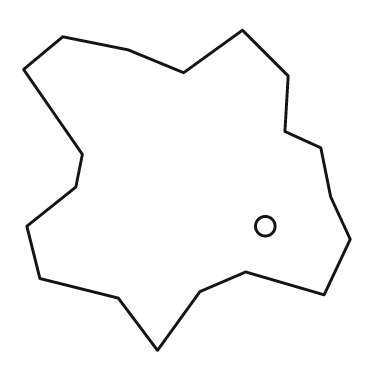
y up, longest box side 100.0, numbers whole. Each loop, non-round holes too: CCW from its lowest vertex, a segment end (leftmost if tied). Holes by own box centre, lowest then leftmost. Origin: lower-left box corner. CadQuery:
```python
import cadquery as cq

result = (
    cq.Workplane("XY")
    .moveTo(41.0, 0.0)
    .lineTo(54.0, 18.0)
    .lineTo(68.0, 24.0)
    .lineTo(92.0, 17.0)
    .lineTo(100.0, 34.0)
    .lineTo(94.0, 47.0)
    .lineTo(91.0, 62.0)
    .lineTo(80.0, 67.0)
    .lineTo(81.0, 84.0)
    .lineTo(67.0, 98.0)
    .lineTo(49.0, 85.0)
    .lineTo(32.0, 92.0)
    .lineTo(12.0, 96.0)
    .lineTo(0.0, 86.0)
    .lineTo(18.0, 60.0)
    .lineTo(16.0, 50.0)
    .lineTo(1.0, 38.0)
    .lineTo(5.0, 22.0)
    .lineTo(29.0, 16.0)
    .close()
    .moveTo(74.0, 38.0)
    .circle(3.0)
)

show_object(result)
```